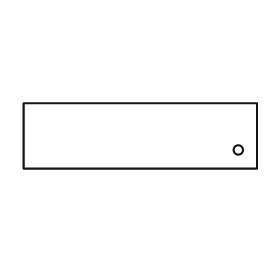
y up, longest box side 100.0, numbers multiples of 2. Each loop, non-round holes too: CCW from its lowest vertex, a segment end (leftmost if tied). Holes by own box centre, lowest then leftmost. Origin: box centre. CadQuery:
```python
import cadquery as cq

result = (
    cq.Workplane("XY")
    .moveTo(-50.0, -14.0)
    .lineTo(50.0, -14.0)
    .lineTo(50.0, 14.0)
    .lineTo(-50.0, 14.0)
    .close()
    .moveTo(42.0, -6.0)
    .circle(2.0)
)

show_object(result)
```